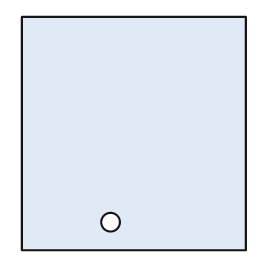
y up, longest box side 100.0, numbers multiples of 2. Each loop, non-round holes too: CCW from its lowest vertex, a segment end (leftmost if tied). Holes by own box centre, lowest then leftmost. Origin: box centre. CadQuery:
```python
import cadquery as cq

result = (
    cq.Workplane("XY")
    .moveTo(-48.0, -50.0)
    .lineTo(48.0, -50.0)
    .lineTo(48.0, 50.0)
    .lineTo(-48.0, 50.0)
    .close()
    .moveTo(-10.0, -38.0)
    .circle(4.0)
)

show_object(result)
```